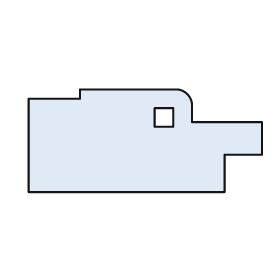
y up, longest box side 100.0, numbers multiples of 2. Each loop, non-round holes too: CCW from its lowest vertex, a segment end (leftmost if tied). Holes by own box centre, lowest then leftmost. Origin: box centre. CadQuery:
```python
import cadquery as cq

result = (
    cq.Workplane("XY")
    .moveTo(-50.0, -22.0)
    .lineTo(34.0, -22.0)
    .lineTo(34.0, -6.0)
    .lineTo(50.0, -6.0)
    .lineTo(50.0, 8.0)
    .lineTo(20.0, 8.0)
    .lineTo(20.0, 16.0)
    .threePointArc((18.0, 20.0), (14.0, 22.0))
    .lineTo(-28.0, 22.0)
    .lineTo(-28.0, 18.0)
    .lineTo(-50.0, 18.0)
    .close()
    .moveTo(4.0, 6.0)
    .lineTo(12.0, 6.0)
    .lineTo(12.0, 14.0)
    .lineTo(4.0, 14.0)
    .close()
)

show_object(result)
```